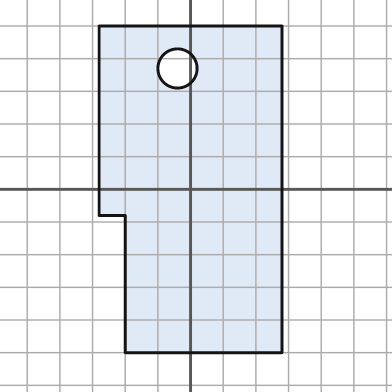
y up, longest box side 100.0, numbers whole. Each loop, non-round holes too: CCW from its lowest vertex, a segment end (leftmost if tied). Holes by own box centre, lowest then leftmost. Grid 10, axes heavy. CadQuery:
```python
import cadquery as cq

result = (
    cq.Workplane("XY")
    .moveTo(-20.0, -50.0)
    .lineTo(28.0, -50.0)
    .lineTo(28.0, 50.0)
    .lineTo(-28.0, 50.0)
    .lineTo(-28.0, -8.0)
    .lineTo(-20.0, -8.0)
    .close()
    .moveTo(-4.0, 37.0)
    .circle(6.0)
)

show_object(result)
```